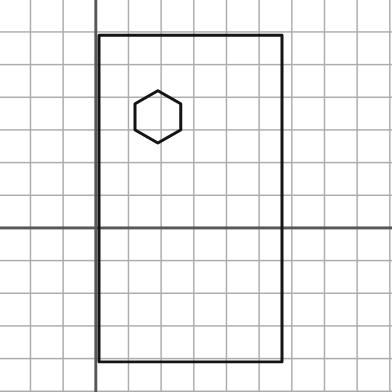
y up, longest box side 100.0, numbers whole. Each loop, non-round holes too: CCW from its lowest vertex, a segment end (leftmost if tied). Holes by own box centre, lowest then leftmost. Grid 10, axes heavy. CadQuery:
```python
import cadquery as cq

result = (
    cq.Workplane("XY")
    .moveTo(1.0, -41.0)
    .lineTo(57.0, -41.0)
    .lineTo(57.0, 59.0)
    .lineTo(1.0, 59.0)
    .close()
    .moveTo(19.0, 26.0)
    .lineTo(26.0, 30.0)
    .lineTo(26.0, 38.0)
    .lineTo(19.0, 42.0)
    .lineTo(12.0, 38.0)
    .lineTo(12.0, 30.0)
    .close()
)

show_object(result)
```